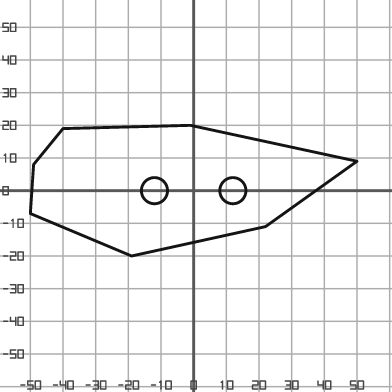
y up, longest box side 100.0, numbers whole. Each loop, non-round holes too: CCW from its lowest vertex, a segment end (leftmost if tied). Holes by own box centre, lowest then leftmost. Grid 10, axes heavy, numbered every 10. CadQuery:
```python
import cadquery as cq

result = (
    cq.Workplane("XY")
    .moveTo(-19.0, -20.0)
    .lineTo(22.0, -11.0)
    .lineTo(50.0, 9.0)
    .lineTo(-1.0, 20.0)
    .lineTo(-40.0, 19.0)
    .lineTo(-49.0, 8.0)
    .lineTo(-50.0, -7.0)
    .close()
    .moveTo(-12.0, 0.0)
    .circle(4.0)
    .moveTo(12.0, 0.0)
    .circle(4.0)
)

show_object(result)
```